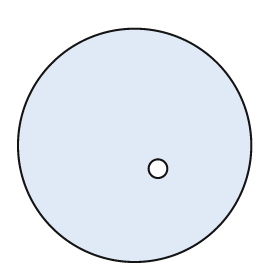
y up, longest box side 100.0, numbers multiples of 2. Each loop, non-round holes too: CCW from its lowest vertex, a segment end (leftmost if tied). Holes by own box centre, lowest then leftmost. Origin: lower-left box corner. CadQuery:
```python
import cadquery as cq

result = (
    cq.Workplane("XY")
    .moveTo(50.0, 50.0)
    .circle(50.0)
    .moveTo(60.0, 40.0)
    .circle(4.0)
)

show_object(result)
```